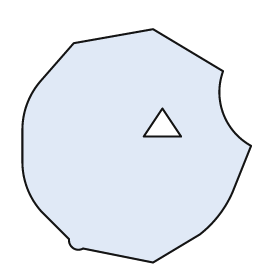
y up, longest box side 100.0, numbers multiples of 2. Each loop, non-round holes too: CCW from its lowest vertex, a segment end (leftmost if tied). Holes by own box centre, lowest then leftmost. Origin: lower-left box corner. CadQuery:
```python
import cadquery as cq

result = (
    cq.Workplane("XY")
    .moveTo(56.0, 0.0)
    .lineTo(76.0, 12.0)
    .threePointArc((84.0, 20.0), (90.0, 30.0))
    .lineTo(98.0, 50.0)
    .threePointArc((86.0, 64.0), (86.0, 82.0))
    .lineTo(56.0, 100.0)
    .lineTo(22.0, 94.0)
    .lineTo(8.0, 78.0)
    .threePointArc((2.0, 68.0), (0.0, 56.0))
    .lineTo(0.0, 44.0)
    .threePointArc((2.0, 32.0), (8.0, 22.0))
    .lineTo(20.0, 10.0)
    .threePointArc((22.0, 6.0), (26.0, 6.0))
    .close()
    .moveTo(52.0, 54.0)
    .lineTo(68.0, 54.0)
    .lineTo(60.0, 66.0)
    .close()
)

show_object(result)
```